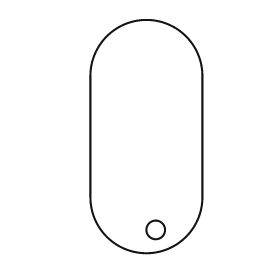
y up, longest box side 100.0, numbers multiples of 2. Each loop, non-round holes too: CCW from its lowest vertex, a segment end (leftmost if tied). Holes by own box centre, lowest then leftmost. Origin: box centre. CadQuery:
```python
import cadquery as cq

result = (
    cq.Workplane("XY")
    .moveTo(-24.0, -26.0)
    .threePointArc((0.0, -50.0), (24.0, -26.0))
    .lineTo(24.0, 26.0)
    .threePointArc((0.0, 50.0), (-24.0, 26.0))
    .close()
    .moveTo(4.0, -40.0)
    .circle(4.0)
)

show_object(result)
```